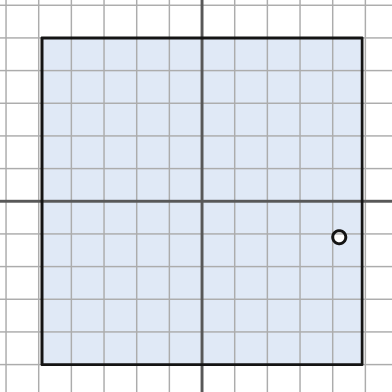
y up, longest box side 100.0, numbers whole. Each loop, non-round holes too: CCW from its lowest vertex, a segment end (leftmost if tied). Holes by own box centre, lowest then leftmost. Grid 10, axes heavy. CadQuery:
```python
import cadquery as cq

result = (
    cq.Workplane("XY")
    .moveTo(-49.0, -50.0)
    .lineTo(49.0, -50.0)
    .lineTo(49.0, 50.0)
    .lineTo(-49.0, 50.0)
    .close()
    .moveTo(42.0, -11.0)
    .circle(2.0)
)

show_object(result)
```